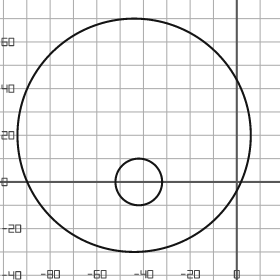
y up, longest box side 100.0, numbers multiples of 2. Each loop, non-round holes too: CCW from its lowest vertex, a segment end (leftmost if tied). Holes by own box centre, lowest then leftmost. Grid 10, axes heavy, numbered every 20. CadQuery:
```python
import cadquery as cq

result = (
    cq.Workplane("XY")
    .moveTo(-44.0, 20.0)
    .circle(50.0)
    .moveTo(-42.0, 0.0)
    .circle(10.0)
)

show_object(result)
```